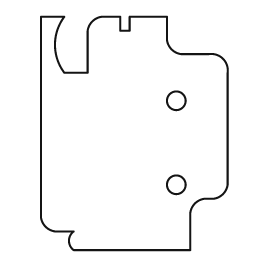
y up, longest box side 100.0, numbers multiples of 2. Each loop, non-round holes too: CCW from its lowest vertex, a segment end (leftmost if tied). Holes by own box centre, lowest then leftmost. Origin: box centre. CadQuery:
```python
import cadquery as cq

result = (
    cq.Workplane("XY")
    .moveTo(-26.0, -50.0)
    .lineTo(24.0, -50.0)
    .lineTo(24.0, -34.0)
    .threePointArc((26.0, -30.0), (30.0, -28.0))
    .lineTo(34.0, -28.0)
    .threePointArc((38.0, -26.0), (40.0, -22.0))
    .lineTo(40.0, 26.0)
    .threePointArc((38.0, 32.0), (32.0, 34.0))
    .lineTo(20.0, 34.0)
    .threePointArc((16.0, 36.0), (14.0, 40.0))
    .lineTo(14.0, 50.0)
    .lineTo(-2.0, 50.0)
    .lineTo(-2.0, 44.0)
    .lineTo(-6.0, 44.0)
    .lineTo(-6.0, 50.0)
    .lineTo(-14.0, 50.0)
    .threePointArc((-18.0, 48.0), (-20.0, 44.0))
    .lineTo(-20.0, 26.0)
    .lineTo(-30.0, 26.0)
    .threePointArc((-34.0, 38.0), (-30.0, 50.0))
    .lineTo(-40.0, 50.0)
    .lineTo(-40.0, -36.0)
    .threePointArc((-38.0, -40.0), (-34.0, -42.0))
    .lineTo(-26.0, -42.0)
    .threePointArc((-28.0, -46.0), (-26.0, -50.0))
    .close()
    .moveTo(18.0, -22.0)
    .circle(4.0)
    .moveTo(18.0, 14.0)
    .circle(4.0)
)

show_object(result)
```